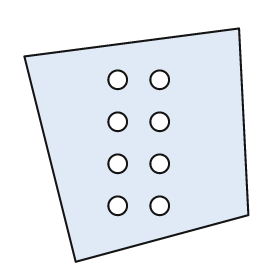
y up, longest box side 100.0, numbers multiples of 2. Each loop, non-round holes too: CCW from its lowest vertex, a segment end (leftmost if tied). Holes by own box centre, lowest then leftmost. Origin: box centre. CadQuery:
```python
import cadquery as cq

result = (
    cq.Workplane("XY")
    .moveTo(-26.0, -50.0)
    .lineTo(48.0, -30.0)
    .lineTo(44.0, 50.0)
    .lineTo(-48.0, 38.0)
    .close()
    .moveTo(-8.0, -26.0)
    .circle(4.0)
    .moveTo(10.0, -26.0)
    .circle(4.0)
    .moveTo(-8.0, -8.0)
    .circle(4.0)
    .moveTo(10.0, -8.0)
    .circle(4.0)
    .moveTo(-8.0, 10.0)
    .circle(4.0)
    .moveTo(10.0, 10.0)
    .circle(4.0)
    .moveTo(-8.0, 28.0)
    .circle(4.0)
    .moveTo(10.0, 28.0)
    .circle(4.0)
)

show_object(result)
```